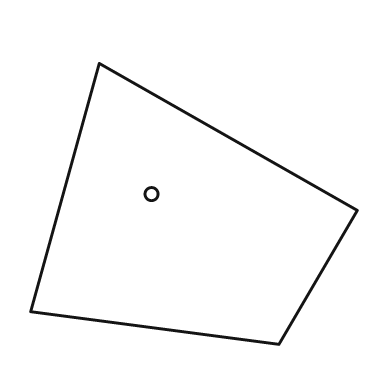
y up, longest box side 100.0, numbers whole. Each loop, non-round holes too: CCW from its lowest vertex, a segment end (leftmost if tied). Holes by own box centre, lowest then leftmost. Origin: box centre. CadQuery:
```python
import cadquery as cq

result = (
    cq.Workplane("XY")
    .moveTo(26.0, -43.0)
    .lineTo(50.0, -2.0)
    .lineTo(-29.0, 43.0)
    .lineTo(-50.0, -33.0)
    .close()
    .moveTo(-13.0, 3.0)
    .circle(2.0)
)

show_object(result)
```